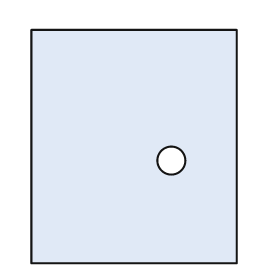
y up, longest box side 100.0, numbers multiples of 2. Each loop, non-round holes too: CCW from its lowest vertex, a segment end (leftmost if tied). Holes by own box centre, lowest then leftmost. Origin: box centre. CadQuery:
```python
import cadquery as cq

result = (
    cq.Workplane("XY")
    .moveTo(-44.0, -50.0)
    .lineTo(44.0, -50.0)
    .lineTo(44.0, 50.0)
    .lineTo(-44.0, 50.0)
    .close()
    .moveTo(16.0, -6.0)
    .circle(6.0)
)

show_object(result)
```